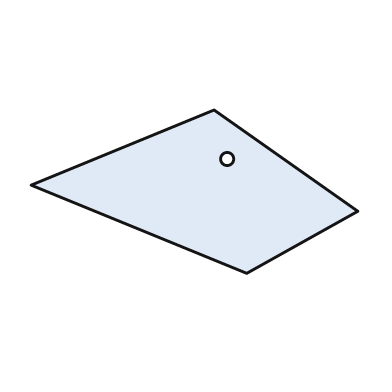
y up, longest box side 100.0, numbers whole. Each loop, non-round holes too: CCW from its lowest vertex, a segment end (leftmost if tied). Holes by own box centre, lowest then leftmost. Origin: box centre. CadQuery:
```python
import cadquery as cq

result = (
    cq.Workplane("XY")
    .moveTo(16.0, -25.0)
    .lineTo(50.0, -6.0)
    .lineTo(6.0, 25.0)
    .lineTo(-50.0, 2.0)
    .close()
    .moveTo(10.0, 10.0)
    .circle(2.0)
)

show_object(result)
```